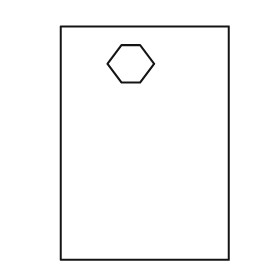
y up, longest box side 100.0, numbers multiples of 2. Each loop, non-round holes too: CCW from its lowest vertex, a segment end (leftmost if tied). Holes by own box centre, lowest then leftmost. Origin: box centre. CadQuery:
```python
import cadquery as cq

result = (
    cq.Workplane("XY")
    .moveTo(-36.0, -50.0)
    .lineTo(36.0, -50.0)
    .lineTo(36.0, 50.0)
    .lineTo(-36.0, 50.0)
    .close()
    .moveTo(-10.0, 26.0)
    .lineTo(-2.0, 26.0)
    .lineTo(4.0, 34.0)
    .lineTo(-2.0, 42.0)
    .lineTo(-10.0, 42.0)
    .lineTo(-16.0, 34.0)
    .close()
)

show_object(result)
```